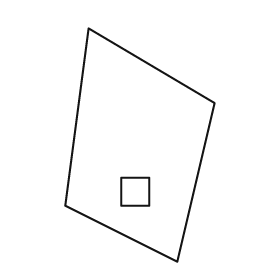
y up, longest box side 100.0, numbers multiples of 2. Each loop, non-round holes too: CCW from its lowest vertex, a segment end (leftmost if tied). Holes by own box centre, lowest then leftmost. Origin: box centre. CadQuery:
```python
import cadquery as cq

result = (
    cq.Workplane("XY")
    .moveTo(16.0, -50.0)
    .lineTo(32.0, 18.0)
    .lineTo(-22.0, 50.0)
    .lineTo(-32.0, -26.0)
    .close()
    .moveTo(-8.0, -26.0)
    .lineTo(4.0, -26.0)
    .lineTo(4.0, -14.0)
    .lineTo(-8.0, -14.0)
    .close()
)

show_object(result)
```